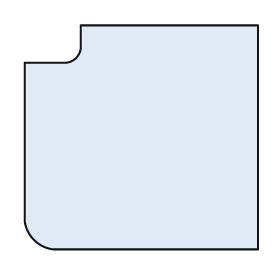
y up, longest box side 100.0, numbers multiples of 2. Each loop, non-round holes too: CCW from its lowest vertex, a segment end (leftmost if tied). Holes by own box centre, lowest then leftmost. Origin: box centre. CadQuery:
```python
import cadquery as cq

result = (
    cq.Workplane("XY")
    .moveTo(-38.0, -48.0)
    .lineTo(50.0, -48.0)
    .lineTo(50.0, 48.0)
    .lineTo(-26.0, 48.0)
    .lineTo(-26.0, 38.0)
    .threePointArc((-28.0, 34.0), (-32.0, 32.0))
    .lineTo(-50.0, 32.0)
    .lineTo(-50.0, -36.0)
    .threePointArc((-46.0, -44.0), (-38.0, -48.0))
    .close()
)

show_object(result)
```